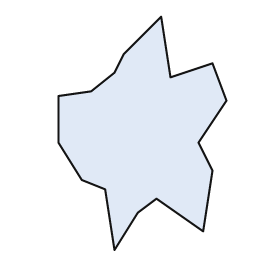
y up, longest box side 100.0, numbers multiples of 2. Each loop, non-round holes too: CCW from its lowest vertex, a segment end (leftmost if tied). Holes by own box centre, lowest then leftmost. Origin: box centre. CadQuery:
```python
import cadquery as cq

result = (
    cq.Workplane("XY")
    .moveTo(-12.0, -50.0)
    .lineTo(-2.0, -34.0)
    .lineTo(6.0, -28.0)
    .lineTo(26.0, -42.0)
    .lineTo(30.0, -16.0)
    .lineTo(24.0, -4.0)
    .lineTo(36.0, 14.0)
    .lineTo(30.0, 30.0)
    .lineTo(12.0, 24.0)
    .lineTo(8.0, 50.0)
    .lineTo(-8.0, 34.0)
    .lineTo(-12.0, 26.0)
    .lineTo(-22.0, 18.0)
    .lineTo(-36.0, 16.0)
    .lineTo(-36.0, -4.0)
    .lineTo(-26.0, -20.0)
    .lineTo(-16.0, -24.0)
    .close()
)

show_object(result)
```